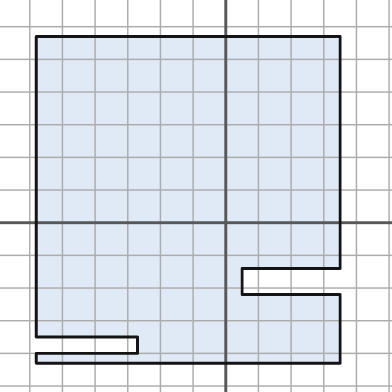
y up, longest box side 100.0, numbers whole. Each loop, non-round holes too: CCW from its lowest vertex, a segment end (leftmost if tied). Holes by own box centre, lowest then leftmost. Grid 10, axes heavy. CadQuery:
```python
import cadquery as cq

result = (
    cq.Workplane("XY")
    .moveTo(-58.0, -43.0)
    .lineTo(35.0, -43.0)
    .lineTo(35.0, -22.0)
    .lineTo(5.0, -22.0)
    .lineTo(5.0, -14.0)
    .lineTo(35.0, -14.0)
    .lineTo(35.0, 57.0)
    .lineTo(-58.0, 57.0)
    .lineTo(-58.0, -35.0)
    .lineTo(-27.0, -35.0)
    .lineTo(-27.0, -40.0)
    .lineTo(-58.0, -40.0)
    .close()
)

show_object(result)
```